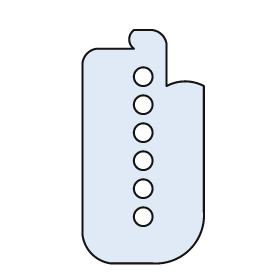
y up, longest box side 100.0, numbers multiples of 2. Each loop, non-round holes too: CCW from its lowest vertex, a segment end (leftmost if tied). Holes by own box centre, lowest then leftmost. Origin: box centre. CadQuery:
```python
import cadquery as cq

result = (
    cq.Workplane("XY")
    .moveTo(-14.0, -50.0)
    .lineTo(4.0, -50.0)
    .threePointArc((20.0, -44.0), (26.0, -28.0))
    .lineTo(26.0, 26.0)
    .threePointArc((18.0, 28.0), (10.0, 26.0))
    .lineTo(10.0, 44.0)
    .threePointArc((8.0, 48.0), (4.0, 50.0))
    .lineTo(-4.0, 50.0)
    .threePointArc((-6.0, 46.0), (-4.0, 42.0))
    .lineTo(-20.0, 42.0)
    .threePointArc((-24.0, 40.0), (-26.0, 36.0))
    .lineTo(-26.0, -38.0)
    .threePointArc((-22.0, -46.0), (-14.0, -50.0))
    .close()
    .moveTo(0.0, -30.0)
    .circle(4.0)
    .moveTo(0.0, -18.0)
    .circle(4.0)
    .moveTo(0.0, -6.0)
    .circle(4.0)
    .moveTo(0.0, 6.0)
    .circle(4.0)
    .moveTo(0.0, 18.0)
    .circle(4.0)
    .moveTo(0.0, 30.0)
    .circle(4.0)
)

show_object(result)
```